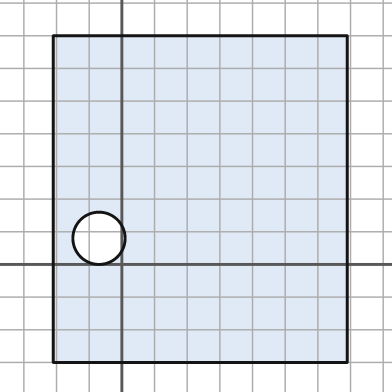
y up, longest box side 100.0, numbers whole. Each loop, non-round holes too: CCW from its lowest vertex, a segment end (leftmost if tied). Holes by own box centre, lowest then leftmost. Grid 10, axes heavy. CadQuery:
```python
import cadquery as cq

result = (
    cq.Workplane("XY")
    .moveTo(-21.0, -30.0)
    .lineTo(69.0, -30.0)
    .lineTo(69.0, 70.0)
    .lineTo(-21.0, 70.0)
    .close()
    .moveTo(-7.0, 8.0)
    .circle(8.0)
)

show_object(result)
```